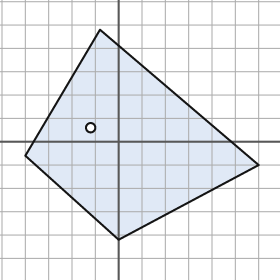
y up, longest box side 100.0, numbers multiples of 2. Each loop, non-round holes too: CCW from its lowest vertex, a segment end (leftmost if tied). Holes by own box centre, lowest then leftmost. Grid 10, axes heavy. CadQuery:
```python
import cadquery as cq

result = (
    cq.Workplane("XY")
    .moveTo(0.0, -42.0)
    .lineTo(60.0, -10.0)
    .lineTo(-8.0, 48.0)
    .lineTo(-40.0, -6.0)
    .close()
    .moveTo(-12.0, 6.0)
    .circle(2.0)
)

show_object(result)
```